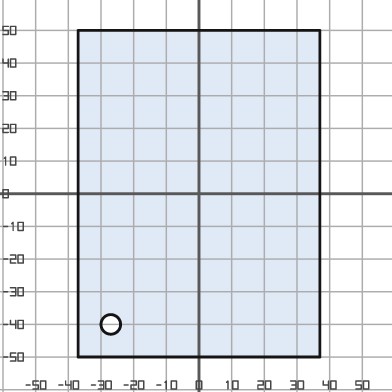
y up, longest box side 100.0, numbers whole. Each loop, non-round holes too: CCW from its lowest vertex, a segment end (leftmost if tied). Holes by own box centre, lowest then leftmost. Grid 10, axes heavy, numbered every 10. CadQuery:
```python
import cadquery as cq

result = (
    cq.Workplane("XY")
    .moveTo(-37.0, -50.0)
    .lineTo(37.0, -50.0)
    .lineTo(37.0, 50.0)
    .lineTo(-37.0, 50.0)
    .close()
    .moveTo(-27.0, -40.0)
    .circle(3.0)
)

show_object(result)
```